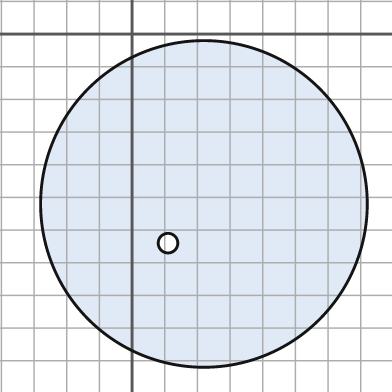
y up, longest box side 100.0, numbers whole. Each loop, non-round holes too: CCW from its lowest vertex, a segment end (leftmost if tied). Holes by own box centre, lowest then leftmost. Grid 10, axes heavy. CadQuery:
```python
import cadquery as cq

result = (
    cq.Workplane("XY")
    .moveTo(22.0, -52.0)
    .circle(50.0)
    .moveTo(11.0, -64.0)
    .circle(3.0)
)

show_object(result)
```